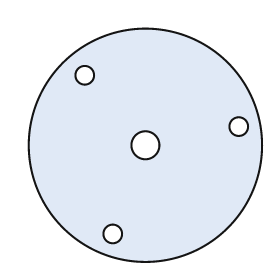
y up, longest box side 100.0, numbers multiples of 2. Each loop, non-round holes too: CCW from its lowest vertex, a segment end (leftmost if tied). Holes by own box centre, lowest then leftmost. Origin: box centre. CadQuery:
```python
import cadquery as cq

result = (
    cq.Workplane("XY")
    .moveTo(0.0, 0.0)
    .circle(50.0)
    .moveTo(-14.0, -38.0)
    .circle(4.0)
    .moveTo(0.0, 0.0)
    .circle(6.0)
    .moveTo(40.0, 8.0)
    .circle(4.0)
    .moveTo(-26.0, 30.0)
    .circle(4.0)
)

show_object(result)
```